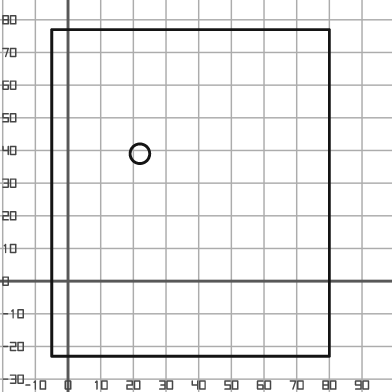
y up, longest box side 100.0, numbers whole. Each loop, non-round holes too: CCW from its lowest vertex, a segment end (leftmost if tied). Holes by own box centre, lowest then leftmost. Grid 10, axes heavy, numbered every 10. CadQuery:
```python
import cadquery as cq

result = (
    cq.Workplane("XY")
    .moveTo(-5.0, -23.0)
    .lineTo(80.0, -23.0)
    .lineTo(80.0, 77.0)
    .lineTo(-5.0, 77.0)
    .close()
    .moveTo(22.0, 39.0)
    .circle(3.0)
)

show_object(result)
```